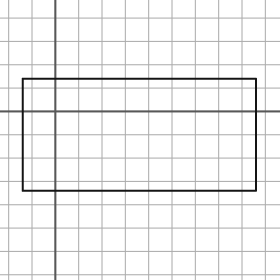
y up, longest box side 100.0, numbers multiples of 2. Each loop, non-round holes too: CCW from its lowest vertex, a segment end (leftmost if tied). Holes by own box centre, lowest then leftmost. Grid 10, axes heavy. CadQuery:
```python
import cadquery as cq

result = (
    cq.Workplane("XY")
    .moveTo(-14.0, -34.0)
    .lineTo(86.0, -34.0)
    .lineTo(86.0, 14.0)
    .lineTo(-14.0, 14.0)
    .close()
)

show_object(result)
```